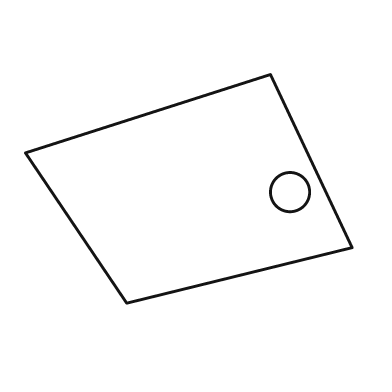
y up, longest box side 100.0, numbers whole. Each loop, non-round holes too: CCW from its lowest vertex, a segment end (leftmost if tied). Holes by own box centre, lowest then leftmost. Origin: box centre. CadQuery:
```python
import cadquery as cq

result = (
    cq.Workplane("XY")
    .moveTo(-19.0, -35.0)
    .lineTo(50.0, -18.0)
    .lineTo(25.0, 35.0)
    .lineTo(-50.0, 11.0)
    .close()
    .moveTo(31.0, -1.0)
    .circle(6.0)
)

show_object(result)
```